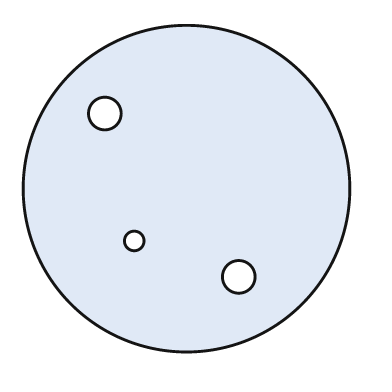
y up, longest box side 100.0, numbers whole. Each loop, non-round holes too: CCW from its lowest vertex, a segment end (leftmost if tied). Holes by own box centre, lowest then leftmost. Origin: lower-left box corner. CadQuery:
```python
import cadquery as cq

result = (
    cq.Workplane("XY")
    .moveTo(50.0, 50.0)
    .circle(50.0)
    .moveTo(66.0, 23.0)
    .circle(5.0)
    .moveTo(34.0, 34.0)
    .circle(3.0)
    .moveTo(25.0, 73.0)
    .circle(5.0)
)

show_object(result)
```